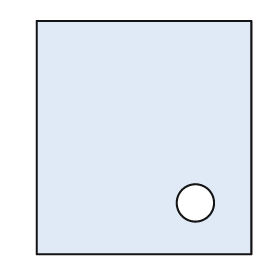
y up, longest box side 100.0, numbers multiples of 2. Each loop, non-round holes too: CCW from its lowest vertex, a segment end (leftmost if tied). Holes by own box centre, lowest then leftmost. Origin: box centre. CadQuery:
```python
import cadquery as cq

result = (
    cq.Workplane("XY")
    .moveTo(-46.0, -50.0)
    .lineTo(46.0, -50.0)
    .lineTo(46.0, 50.0)
    .lineTo(-46.0, 50.0)
    .close()
    .moveTo(22.0, -28.0)
    .circle(8.0)
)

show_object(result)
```